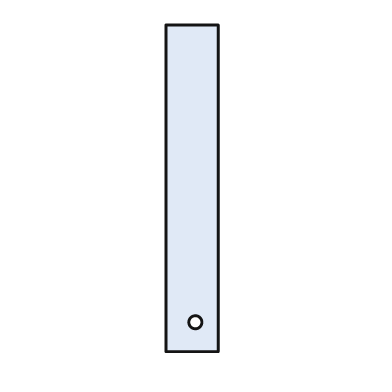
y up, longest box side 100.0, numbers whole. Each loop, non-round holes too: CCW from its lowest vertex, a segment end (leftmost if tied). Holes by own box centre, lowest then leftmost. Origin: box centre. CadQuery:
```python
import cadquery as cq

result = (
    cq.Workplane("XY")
    .moveTo(-8.0, -50.0)
    .lineTo(8.0, -50.0)
    .lineTo(8.0, 50.0)
    .lineTo(-8.0, 50.0)
    .close()
    .moveTo(1.0, -41.0)
    .circle(2.0)
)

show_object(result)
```